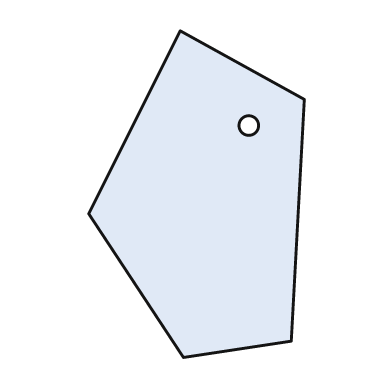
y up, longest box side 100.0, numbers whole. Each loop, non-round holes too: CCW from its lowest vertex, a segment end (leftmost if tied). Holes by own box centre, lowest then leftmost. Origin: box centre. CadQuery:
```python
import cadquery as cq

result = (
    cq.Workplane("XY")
    .moveTo(-4.0, -50.0)
    .lineTo(29.0, -45.0)
    .lineTo(33.0, 29.0)
    .lineTo(-5.0, 50.0)
    .lineTo(-33.0, -6.0)
    .close()
    .moveTo(16.0, 21.0)
    .circle(3.0)
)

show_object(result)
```